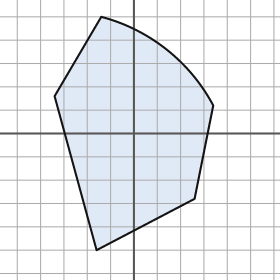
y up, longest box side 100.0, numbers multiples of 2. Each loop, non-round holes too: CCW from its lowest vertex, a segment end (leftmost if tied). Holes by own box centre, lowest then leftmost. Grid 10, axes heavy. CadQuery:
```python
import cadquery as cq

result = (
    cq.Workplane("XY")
    .moveTo(-16.0, -50.0)
    .lineTo(26.0, -28.0)
    .lineTo(34.0, 12.0)
    .threePointArc((14.0, 36.0), (-14.0, 50.0))
    .lineTo(-34.0, 16.0)
    .close()
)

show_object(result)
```